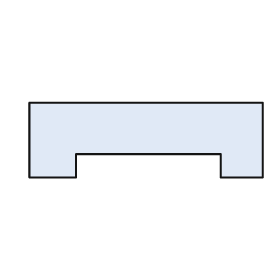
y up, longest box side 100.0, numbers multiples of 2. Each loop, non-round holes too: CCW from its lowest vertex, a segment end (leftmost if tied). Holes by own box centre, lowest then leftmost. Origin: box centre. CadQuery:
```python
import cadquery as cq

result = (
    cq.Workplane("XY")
    .moveTo(-50.0, -16.0)
    .lineTo(-30.0, -16.0)
    .lineTo(-30.0, -6.0)
    .lineTo(32.0, -6.0)
    .lineTo(32.0, -16.0)
    .lineTo(50.0, -16.0)
    .lineTo(50.0, 16.0)
    .lineTo(-50.0, 16.0)
    .close()
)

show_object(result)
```